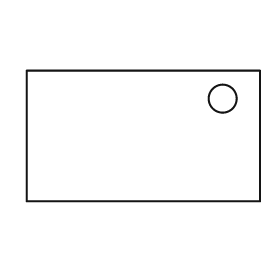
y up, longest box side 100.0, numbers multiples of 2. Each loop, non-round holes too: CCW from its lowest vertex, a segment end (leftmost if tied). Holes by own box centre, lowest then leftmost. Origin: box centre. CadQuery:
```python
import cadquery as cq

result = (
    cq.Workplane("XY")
    .moveTo(-50.0, -28.0)
    .lineTo(50.0, -28.0)
    .lineTo(50.0, 28.0)
    .lineTo(-50.0, 28.0)
    .close()
    .moveTo(34.0, 16.0)
    .circle(6.0)
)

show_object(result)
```